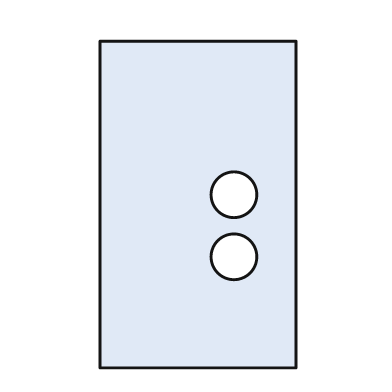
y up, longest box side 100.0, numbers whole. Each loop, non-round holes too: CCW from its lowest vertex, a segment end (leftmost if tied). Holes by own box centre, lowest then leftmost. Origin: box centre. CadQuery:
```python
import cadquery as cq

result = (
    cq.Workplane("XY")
    .moveTo(-30.0, -50.0)
    .lineTo(30.0, -50.0)
    .lineTo(30.0, 50.0)
    .lineTo(-30.0, 50.0)
    .close()
    .moveTo(11.0, -16.0)
    .circle(7.0)
    .moveTo(11.0, 3.0)
    .circle(7.0)
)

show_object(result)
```